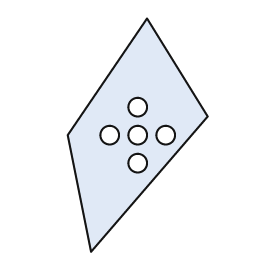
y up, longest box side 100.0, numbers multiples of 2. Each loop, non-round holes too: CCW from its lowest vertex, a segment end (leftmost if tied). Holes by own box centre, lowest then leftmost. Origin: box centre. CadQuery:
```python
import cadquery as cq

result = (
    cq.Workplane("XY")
    .moveTo(-20.0, -50.0)
    .lineTo(30.0, 8.0)
    .lineTo(4.0, 50.0)
    .lineTo(-30.0, 0.0)
    .close()
    .moveTo(0.0, -12.0)
    .circle(4.0)
    .moveTo(-12.0, 0.0)
    .circle(4.0)
    .moveTo(0.0, 0.0)
    .circle(4.0)
    .moveTo(12.0, 0.0)
    .circle(4.0)
    .moveTo(0.0, 12.0)
    .circle(4.0)
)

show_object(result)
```